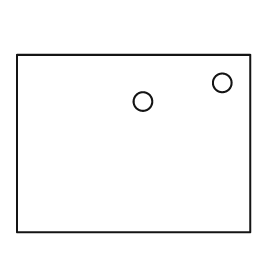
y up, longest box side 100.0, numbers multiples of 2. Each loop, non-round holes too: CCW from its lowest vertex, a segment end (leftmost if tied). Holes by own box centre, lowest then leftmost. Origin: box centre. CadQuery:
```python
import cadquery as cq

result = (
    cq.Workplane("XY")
    .moveTo(-50.0, -38.0)
    .lineTo(50.0, -38.0)
    .lineTo(50.0, 38.0)
    .lineTo(-50.0, 38.0)
    .close()
    .moveTo(4.0, 18.0)
    .circle(4.0)
    .moveTo(38.0, 26.0)
    .circle(4.0)
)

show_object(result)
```